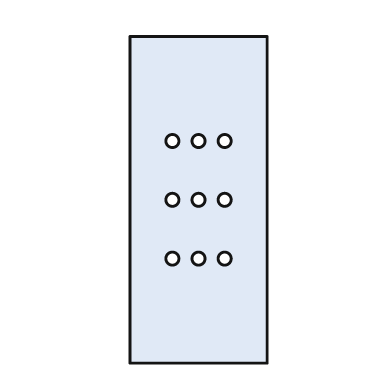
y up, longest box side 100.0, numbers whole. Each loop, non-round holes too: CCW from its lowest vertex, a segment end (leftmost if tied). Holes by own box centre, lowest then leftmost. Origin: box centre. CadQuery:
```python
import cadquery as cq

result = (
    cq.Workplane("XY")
    .moveTo(-21.0, -50.0)
    .lineTo(21.0, -50.0)
    .lineTo(21.0, 50.0)
    .lineTo(-21.0, 50.0)
    .close()
    .moveTo(-8.0, -18.0)
    .circle(2.0)
    .moveTo(0.0, -18.0)
    .circle(2.0)
    .moveTo(8.0, -18.0)
    .circle(2.0)
    .moveTo(-8.0, 0.0)
    .circle(2.0)
    .moveTo(0.0, 0.0)
    .circle(2.0)
    .moveTo(8.0, 0.0)
    .circle(2.0)
    .moveTo(-8.0, 18.0)
    .circle(2.0)
    .moveTo(0.0, 18.0)
    .circle(2.0)
    .moveTo(8.0, 18.0)
    .circle(2.0)
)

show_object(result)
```